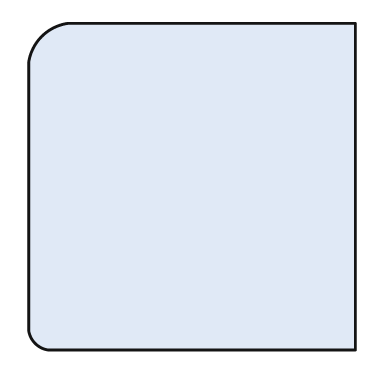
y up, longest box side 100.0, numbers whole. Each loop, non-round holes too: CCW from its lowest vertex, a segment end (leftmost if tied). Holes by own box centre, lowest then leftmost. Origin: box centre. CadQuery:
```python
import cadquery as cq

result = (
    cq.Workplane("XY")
    .moveTo(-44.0, -50.0)
    .lineTo(50.0, -50.0)
    .lineTo(50.0, 50.0)
    .lineTo(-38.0, 50.0)
    .threePointArc((-46.0, 46.0), (-50.0, 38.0))
    .lineTo(-50.0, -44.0)
    .threePointArc((-48.0, -48.0), (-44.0, -50.0))
    .close()
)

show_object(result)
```